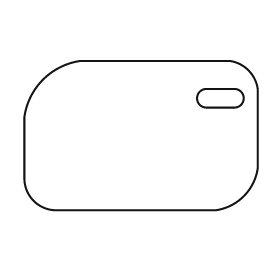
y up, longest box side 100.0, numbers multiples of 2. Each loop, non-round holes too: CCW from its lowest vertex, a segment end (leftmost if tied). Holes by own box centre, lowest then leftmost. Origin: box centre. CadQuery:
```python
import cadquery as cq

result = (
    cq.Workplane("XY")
    .moveTo(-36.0, -32.0)
    .lineTo(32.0, -32.0)
    .threePointArc((44.0, -26.0), (50.0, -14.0))
    .lineTo(50.0, 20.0)
    .threePointArc((46.0, 28.0), (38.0, 32.0))
    .lineTo(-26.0, 32.0)
    .threePointArc((-42.0, 24.0), (-50.0, 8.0))
    .lineTo(-50.0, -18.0)
    .threePointArc((-46.0, -28.0), (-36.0, -32.0))
    .close()
    .moveTo(28.0, 12.0)
    .lineTo(40.0, 12.0)
    .threePointArc((44.0, 16.0), (40.0, 20.0))
    .lineTo(28.0, 20.0)
    .threePointArc((24.0, 16.0), (28.0, 12.0))
    .close()
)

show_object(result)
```